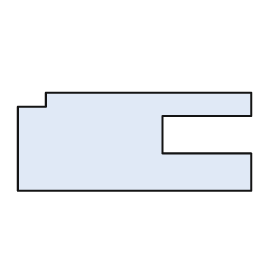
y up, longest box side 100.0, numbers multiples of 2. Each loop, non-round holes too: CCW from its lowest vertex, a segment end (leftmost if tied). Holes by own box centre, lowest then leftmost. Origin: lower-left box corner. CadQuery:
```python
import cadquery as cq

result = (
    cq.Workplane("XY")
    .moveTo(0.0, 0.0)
    .lineTo(100.0, 0.0)
    .lineTo(100.0, 16.0)
    .lineTo(62.0, 16.0)
    .lineTo(62.0, 32.0)
    .lineTo(100.0, 32.0)
    .lineTo(100.0, 42.0)
    .lineTo(12.0, 42.0)
    .lineTo(12.0, 36.0)
    .lineTo(0.0, 36.0)
    .close()
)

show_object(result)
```